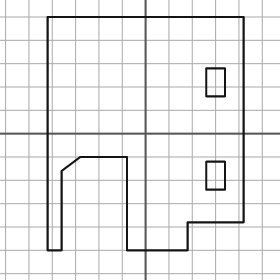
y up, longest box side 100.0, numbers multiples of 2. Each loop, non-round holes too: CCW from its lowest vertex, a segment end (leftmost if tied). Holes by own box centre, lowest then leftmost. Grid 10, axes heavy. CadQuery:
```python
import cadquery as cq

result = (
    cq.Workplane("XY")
    .moveTo(-42.0, -50.0)
    .lineTo(-36.0, -50.0)
    .lineTo(-36.0, -16.0)
    .lineTo(-28.0, -10.0)
    .lineTo(-8.0, -10.0)
    .lineTo(-8.0, -50.0)
    .lineTo(18.0, -50.0)
    .lineTo(18.0, -38.0)
    .lineTo(42.0, -38.0)
    .lineTo(42.0, 50.0)
    .lineTo(-42.0, 50.0)
    .close()
    .moveTo(26.0, -24.0)
    .lineTo(34.0, -24.0)
    .lineTo(34.0, -12.0)
    .lineTo(26.0, -12.0)
    .close()
    .moveTo(26.0, 16.0)
    .lineTo(34.0, 16.0)
    .lineTo(34.0, 28.0)
    .lineTo(26.0, 28.0)
    .close()
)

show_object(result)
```